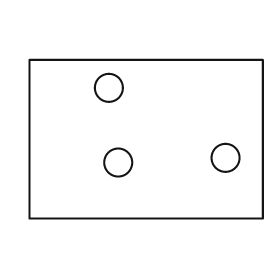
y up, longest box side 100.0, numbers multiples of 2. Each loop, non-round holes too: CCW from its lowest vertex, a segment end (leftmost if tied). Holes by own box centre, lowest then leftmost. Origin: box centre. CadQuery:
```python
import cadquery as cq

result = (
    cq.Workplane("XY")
    .moveTo(-50.0, -34.0)
    .lineTo(50.0, -34.0)
    .lineTo(50.0, 34.0)
    .lineTo(-50.0, 34.0)
    .close()
    .moveTo(-12.0, -10.0)
    .circle(6.0)
    .moveTo(34.0, -8.0)
    .circle(6.0)
    .moveTo(-16.0, 22.0)
    .circle(6.0)
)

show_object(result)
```